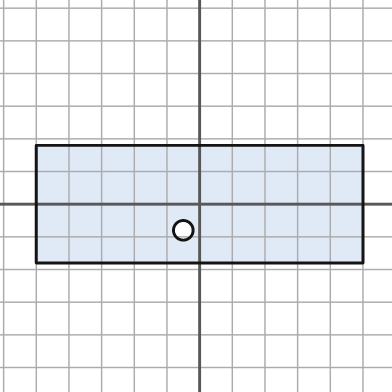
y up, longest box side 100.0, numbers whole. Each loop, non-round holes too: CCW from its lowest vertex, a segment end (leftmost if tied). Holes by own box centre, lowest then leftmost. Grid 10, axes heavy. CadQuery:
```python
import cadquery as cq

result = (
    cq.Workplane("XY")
    .moveTo(-50.0, -18.0)
    .lineTo(50.0, -18.0)
    .lineTo(50.0, 18.0)
    .lineTo(-50.0, 18.0)
    .close()
    .moveTo(-5.0, -8.0)
    .circle(3.0)
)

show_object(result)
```